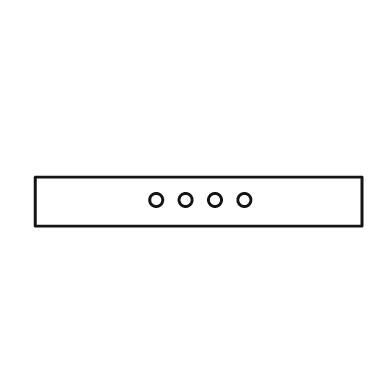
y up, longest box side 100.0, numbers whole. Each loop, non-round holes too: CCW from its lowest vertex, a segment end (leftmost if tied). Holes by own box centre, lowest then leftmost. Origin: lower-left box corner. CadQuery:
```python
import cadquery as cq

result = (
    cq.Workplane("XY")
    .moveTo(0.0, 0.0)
    .lineTo(100.0, 0.0)
    .lineTo(100.0, 15.0)
    .lineTo(0.0, 15.0)
    .close()
    .moveTo(37.0, 8.0)
    .circle(2.0)
    .moveTo(46.0, 8.0)
    .circle(2.0)
    .moveTo(55.0, 8.0)
    .circle(2.0)
    .moveTo(64.0, 8.0)
    .circle(2.0)
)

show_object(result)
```